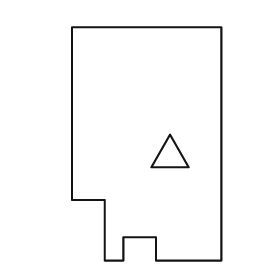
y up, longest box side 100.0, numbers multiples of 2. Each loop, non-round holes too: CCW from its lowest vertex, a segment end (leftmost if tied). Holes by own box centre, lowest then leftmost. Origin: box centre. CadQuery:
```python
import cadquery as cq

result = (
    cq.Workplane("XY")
    .moveTo(-18.0, -50.0)
    .lineTo(-10.0, -50.0)
    .lineTo(-10.0, -40.0)
    .lineTo(4.0, -40.0)
    .lineTo(4.0, -50.0)
    .lineTo(32.0, -50.0)
    .lineTo(32.0, 50.0)
    .lineTo(-32.0, 50.0)
    .lineTo(-32.0, -24.0)
    .lineTo(-18.0, -24.0)
    .close()
    .moveTo(2.0, -10.0)
    .lineTo(18.0, -10.0)
    .lineTo(10.0, 4.0)
    .close()
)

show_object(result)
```